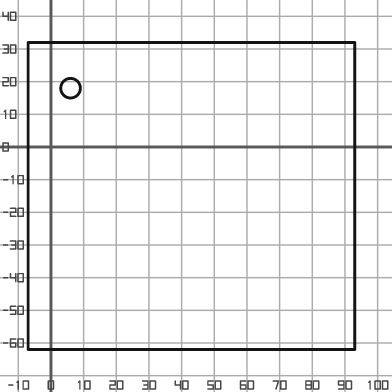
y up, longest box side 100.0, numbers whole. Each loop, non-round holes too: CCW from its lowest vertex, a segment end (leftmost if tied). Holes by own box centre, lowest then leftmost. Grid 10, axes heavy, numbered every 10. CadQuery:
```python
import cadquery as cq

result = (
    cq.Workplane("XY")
    .moveTo(-7.0, -62.0)
    .lineTo(93.0, -62.0)
    .lineTo(93.0, 32.0)
    .lineTo(-7.0, 32.0)
    .close()
    .moveTo(6.0, 18.0)
    .circle(3.0)
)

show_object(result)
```